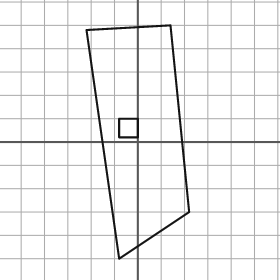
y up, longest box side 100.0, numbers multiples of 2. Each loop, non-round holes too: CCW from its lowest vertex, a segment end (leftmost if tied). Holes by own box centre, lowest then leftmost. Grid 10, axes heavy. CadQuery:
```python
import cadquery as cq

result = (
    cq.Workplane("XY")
    .moveTo(-8.0, -50.0)
    .lineTo(22.0, -30.0)
    .lineTo(14.0, 50.0)
    .lineTo(-22.0, 48.0)
    .close()
    .moveTo(-8.0, 2.0)
    .lineTo(0.0, 2.0)
    .lineTo(0.0, 10.0)
    .lineTo(-8.0, 10.0)
    .close()
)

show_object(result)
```